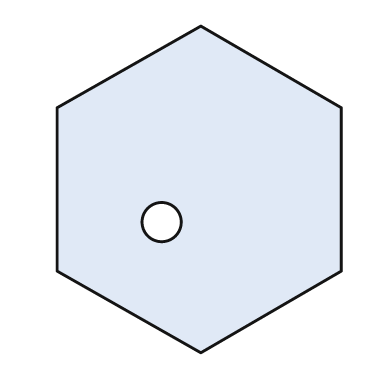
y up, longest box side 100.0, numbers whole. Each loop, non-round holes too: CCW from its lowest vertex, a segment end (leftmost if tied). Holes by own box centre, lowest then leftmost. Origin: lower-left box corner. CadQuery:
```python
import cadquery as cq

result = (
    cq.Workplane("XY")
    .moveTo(44.0, 0.0)
    .lineTo(87.0, 25.0)
    .lineTo(87.0, 75.0)
    .lineTo(44.0, 100.0)
    .lineTo(0.0, 75.0)
    .lineTo(0.0, 25.0)
    .close()
    .moveTo(32.0, 40.0)
    .circle(6.0)
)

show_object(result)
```